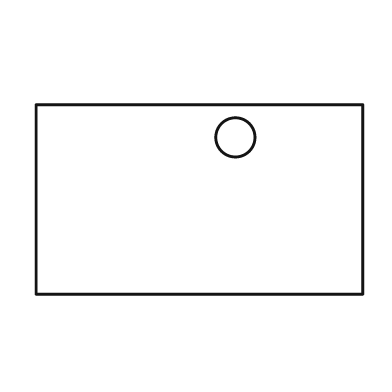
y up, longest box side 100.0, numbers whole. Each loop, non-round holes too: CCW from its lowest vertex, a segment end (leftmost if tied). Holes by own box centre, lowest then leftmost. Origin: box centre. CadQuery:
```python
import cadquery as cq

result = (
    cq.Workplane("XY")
    .moveTo(-50.0, -29.0)
    .lineTo(50.0, -29.0)
    .lineTo(50.0, 29.0)
    .lineTo(-50.0, 29.0)
    .close()
    .moveTo(11.0, 19.0)
    .circle(6.0)
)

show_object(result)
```